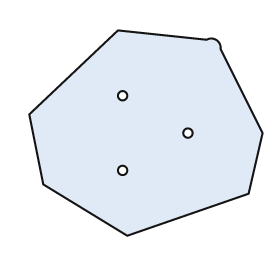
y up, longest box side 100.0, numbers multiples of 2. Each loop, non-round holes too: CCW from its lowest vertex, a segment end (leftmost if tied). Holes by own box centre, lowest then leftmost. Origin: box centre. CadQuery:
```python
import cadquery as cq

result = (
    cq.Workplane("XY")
    .moveTo(-8.0, -44.0)
    .lineTo(44.0, -26.0)
    .lineTo(50.0, 0.0)
    .lineTo(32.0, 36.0)
    .threePointArc((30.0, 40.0), (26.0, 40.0))
    .lineTo(-12.0, 44.0)
    .lineTo(-50.0, 8.0)
    .lineTo(-44.0, -22.0)
    .close()
    .moveTo(-10.0, -16.0)
    .circle(2.0)
    .moveTo(18.0, 0.0)
    .circle(2.0)
    .moveTo(-10.0, 16.0)
    .circle(2.0)
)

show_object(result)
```